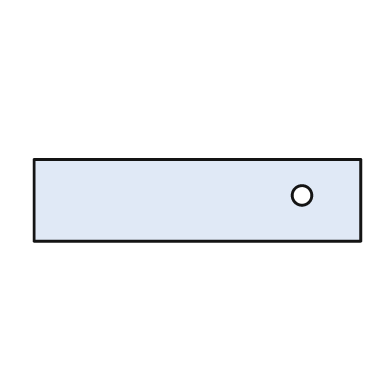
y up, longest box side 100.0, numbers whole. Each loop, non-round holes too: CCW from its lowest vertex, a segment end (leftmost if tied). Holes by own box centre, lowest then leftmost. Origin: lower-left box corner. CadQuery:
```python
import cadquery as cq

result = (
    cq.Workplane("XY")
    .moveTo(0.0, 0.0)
    .lineTo(100.0, 0.0)
    .lineTo(100.0, 25.0)
    .lineTo(0.0, 25.0)
    .close()
    .moveTo(82.0, 14.0)
    .circle(3.0)
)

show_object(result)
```